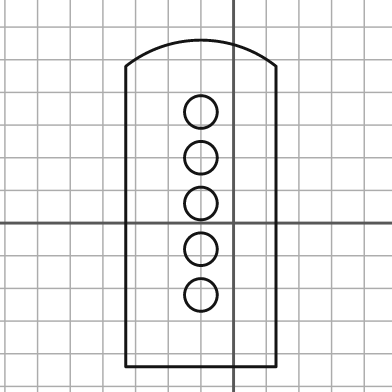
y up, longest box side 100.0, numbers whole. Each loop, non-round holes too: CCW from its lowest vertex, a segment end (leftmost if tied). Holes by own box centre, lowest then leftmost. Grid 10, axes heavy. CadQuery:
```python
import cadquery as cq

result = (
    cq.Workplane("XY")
    .moveTo(-33.0, -44.0)
    .lineTo(13.0, -44.0)
    .lineTo(13.0, 48.0)
    .threePointArc((-10.0, 56.0), (-33.0, 48.0))
    .close()
    .moveTo(-10.0, -22.0)
    .circle(5.0)
    .moveTo(-10.0, -8.0)
    .circle(5.0)
    .moveTo(-10.0, 6.0)
    .circle(5.0)
    .moveTo(-10.0, 20.0)
    .circle(5.0)
    .moveTo(-10.0, 34.0)
    .circle(5.0)
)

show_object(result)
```